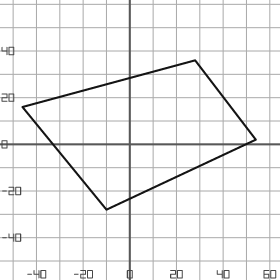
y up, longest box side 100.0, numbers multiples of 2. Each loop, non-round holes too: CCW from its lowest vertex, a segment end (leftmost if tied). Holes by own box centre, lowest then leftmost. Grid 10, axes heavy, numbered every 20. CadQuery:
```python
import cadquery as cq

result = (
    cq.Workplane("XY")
    .moveTo(-10.0, -28.0)
    .lineTo(54.0, 2.0)
    .lineTo(28.0, 36.0)
    .lineTo(-46.0, 16.0)
    .close()
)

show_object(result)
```